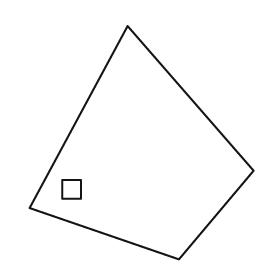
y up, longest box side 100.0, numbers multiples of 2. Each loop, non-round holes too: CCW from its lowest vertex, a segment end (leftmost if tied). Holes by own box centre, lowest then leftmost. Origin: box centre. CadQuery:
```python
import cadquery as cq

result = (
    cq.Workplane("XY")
    .moveTo(16.0, -50.0)
    .lineTo(48.0, -12.0)
    .lineTo(-6.0, 50.0)
    .lineTo(-48.0, -28.0)
    .close()
    .moveTo(-34.0, -24.0)
    .lineTo(-26.0, -24.0)
    .lineTo(-26.0, -16.0)
    .lineTo(-34.0, -16.0)
    .close()
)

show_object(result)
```